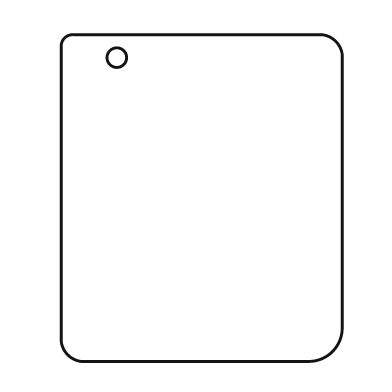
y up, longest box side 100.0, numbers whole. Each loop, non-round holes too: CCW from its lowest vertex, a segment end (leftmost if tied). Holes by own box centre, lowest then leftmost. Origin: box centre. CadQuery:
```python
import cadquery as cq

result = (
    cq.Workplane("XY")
    .moveTo(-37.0, -50.0)
    .lineTo(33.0, -50.0)
    .threePointArc((40.0, -47.0), (43.0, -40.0))
    .lineTo(43.0, 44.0)
    .threePointArc((41.0, 48.0), (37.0, 50.0))
    .lineTo(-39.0, 50.0)
    .threePointArc((-42.0, 49.0), (-43.0, 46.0))
    .lineTo(-43.0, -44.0)
    .threePointArc((-41.0, -48.0), (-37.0, -50.0))
    .close()
    .moveTo(-26.0, 43.0)
    .circle(3.0)
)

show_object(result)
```